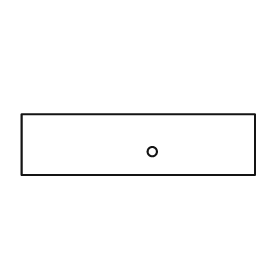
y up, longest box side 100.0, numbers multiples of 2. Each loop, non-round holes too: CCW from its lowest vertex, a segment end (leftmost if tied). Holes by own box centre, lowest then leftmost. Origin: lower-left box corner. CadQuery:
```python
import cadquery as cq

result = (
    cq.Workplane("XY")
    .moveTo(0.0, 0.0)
    .lineTo(100.0, 0.0)
    .lineTo(100.0, 26.0)
    .lineTo(0.0, 26.0)
    .close()
    .moveTo(56.0, 10.0)
    .circle(2.0)
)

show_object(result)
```